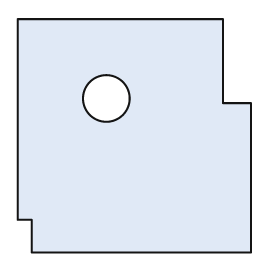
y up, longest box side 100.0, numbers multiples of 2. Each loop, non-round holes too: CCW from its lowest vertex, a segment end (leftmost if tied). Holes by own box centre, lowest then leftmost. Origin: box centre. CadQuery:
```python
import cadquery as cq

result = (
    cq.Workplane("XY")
    .moveTo(-44.0, -50.0)
    .lineTo(50.0, -50.0)
    .lineTo(50.0, 14.0)
    .lineTo(38.0, 14.0)
    .lineTo(38.0, 50.0)
    .lineTo(-50.0, 50.0)
    .lineTo(-50.0, -36.0)
    .lineTo(-44.0, -36.0)
    .close()
    .moveTo(-12.0, 16.0)
    .circle(10.0)
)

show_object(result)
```